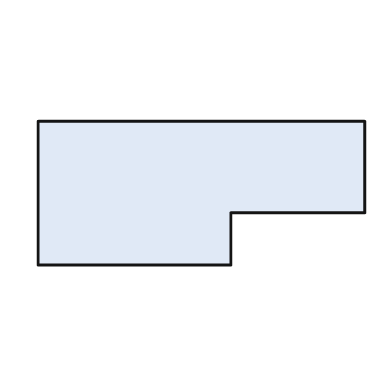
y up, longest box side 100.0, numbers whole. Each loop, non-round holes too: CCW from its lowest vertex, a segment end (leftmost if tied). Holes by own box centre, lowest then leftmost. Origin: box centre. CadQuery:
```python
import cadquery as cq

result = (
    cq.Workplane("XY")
    .moveTo(-50.0, -22.0)
    .lineTo(9.0, -22.0)
    .lineTo(9.0, -6.0)
    .lineTo(50.0, -6.0)
    .lineTo(50.0, 22.0)
    .lineTo(-50.0, 22.0)
    .close()
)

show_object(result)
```